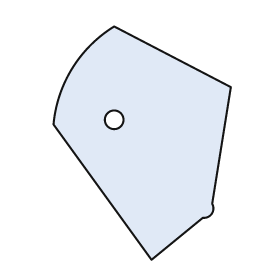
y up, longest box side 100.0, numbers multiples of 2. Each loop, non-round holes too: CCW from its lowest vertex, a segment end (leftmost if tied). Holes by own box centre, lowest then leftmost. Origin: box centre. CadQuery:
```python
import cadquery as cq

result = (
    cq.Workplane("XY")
    .moveTo(4.0, -50.0)
    .lineTo(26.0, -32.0)
    .threePointArc((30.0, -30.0), (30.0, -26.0))
    .lineTo(38.0, 24.0)
    .lineTo(-12.0, 50.0)
    .threePointArc((-30.0, 32.0), (-38.0, 8.0))
    .close()
    .moveTo(-12.0, 10.0)
    .circle(4.0)
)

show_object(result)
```